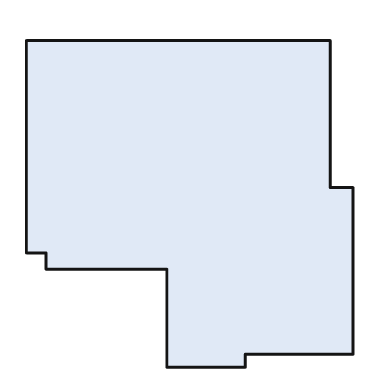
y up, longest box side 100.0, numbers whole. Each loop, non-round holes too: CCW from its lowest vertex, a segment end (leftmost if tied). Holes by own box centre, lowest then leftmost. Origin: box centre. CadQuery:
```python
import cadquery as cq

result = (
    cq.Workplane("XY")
    .moveTo(-7.0, -50.0)
    .lineTo(17.0, -50.0)
    .lineTo(17.0, -46.0)
    .lineTo(50.0, -46.0)
    .lineTo(50.0, 5.0)
    .lineTo(43.0, 5.0)
    .lineTo(43.0, 50.0)
    .lineTo(-50.0, 50.0)
    .lineTo(-50.0, -15.0)
    .lineTo(-44.0, -15.0)
    .lineTo(-44.0, -20.0)
    .lineTo(-7.0, -20.0)
    .close()
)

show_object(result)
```